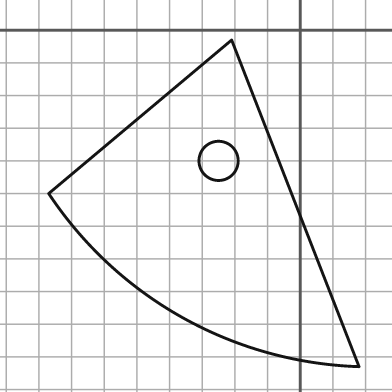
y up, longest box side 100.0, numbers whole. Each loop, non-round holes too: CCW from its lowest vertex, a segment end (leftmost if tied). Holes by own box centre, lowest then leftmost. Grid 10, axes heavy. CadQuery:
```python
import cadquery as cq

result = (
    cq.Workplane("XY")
    .moveTo(18.0, -103.0)
    .lineTo(-21.0, -3.0)
    .lineTo(-77.0, -50.0)
    .threePointArc((-36.0, -88.0), (18.0, -103.0))
    .close()
    .moveTo(-25.0, -40.0)
    .circle(6.0)
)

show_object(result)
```